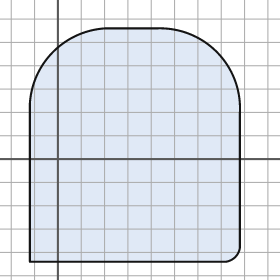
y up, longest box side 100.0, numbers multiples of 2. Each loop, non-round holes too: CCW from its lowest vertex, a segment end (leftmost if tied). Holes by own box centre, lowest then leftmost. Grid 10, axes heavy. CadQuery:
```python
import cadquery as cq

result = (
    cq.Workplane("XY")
    .moveTo(-12.0, -44.0)
    .lineTo(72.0, -44.0)
    .threePointArc((76.0, -42.0), (78.0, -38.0))
    .lineTo(78.0, 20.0)
    .threePointArc((68.0, 46.0), (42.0, 56.0))
    .lineTo(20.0, 56.0)
    .threePointArc((-2.0, 46.0), (-12.0, 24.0))
    .close()
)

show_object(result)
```